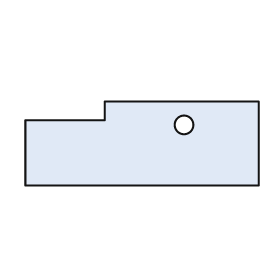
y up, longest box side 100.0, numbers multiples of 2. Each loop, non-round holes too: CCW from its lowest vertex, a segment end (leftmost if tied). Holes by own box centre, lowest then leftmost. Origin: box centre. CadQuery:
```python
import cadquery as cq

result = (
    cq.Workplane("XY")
    .moveTo(-50.0, -18.0)
    .lineTo(50.0, -18.0)
    .lineTo(50.0, 18.0)
    .lineTo(-16.0, 18.0)
    .lineTo(-16.0, 10.0)
    .lineTo(-50.0, 10.0)
    .close()
    .moveTo(18.0, 8.0)
    .circle(4.0)
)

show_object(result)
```